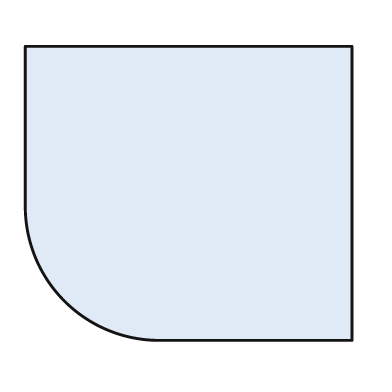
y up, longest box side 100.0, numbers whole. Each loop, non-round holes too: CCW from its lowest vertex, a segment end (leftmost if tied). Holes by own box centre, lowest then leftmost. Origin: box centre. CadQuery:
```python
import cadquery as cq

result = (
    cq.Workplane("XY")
    .moveTo(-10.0, -45.0)
    .lineTo(50.0, -45.0)
    .lineTo(50.0, 45.0)
    .lineTo(-50.0, 45.0)
    .lineTo(-50.0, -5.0)
    .threePointArc((-38.0, -33.0), (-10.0, -45.0))
    .close()
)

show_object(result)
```